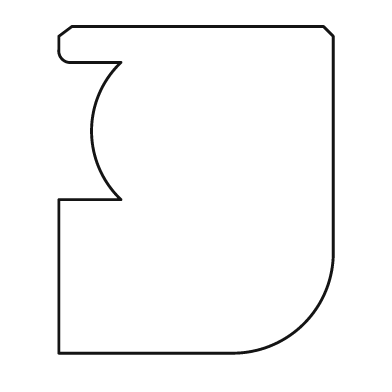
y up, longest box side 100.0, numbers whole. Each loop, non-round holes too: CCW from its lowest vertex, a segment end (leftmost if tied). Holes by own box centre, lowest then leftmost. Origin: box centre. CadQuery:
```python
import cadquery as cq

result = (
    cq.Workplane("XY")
    .moveTo(-42.0, -50.0)
    .lineTo(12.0, -50.0)
    .threePointArc((33.0, -41.0), (42.0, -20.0))
    .lineTo(42.0, 47.0)
    .lineTo(39.0, 50.0)
    .lineTo(-38.0, 50.0)
    .lineTo(-42.0, 47.0)
    .lineTo(-42.0, 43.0)
    .threePointArc((-41.0, 40.0), (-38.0, 39.0))
    .lineTo(-23.0, 39.0)
    .threePointArc((-32.0, 18.0), (-23.0, -3.0))
    .lineTo(-42.0, -3.0)
    .close()
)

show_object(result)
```